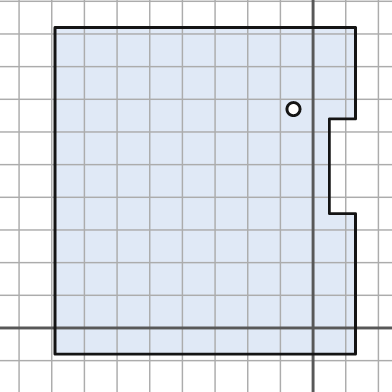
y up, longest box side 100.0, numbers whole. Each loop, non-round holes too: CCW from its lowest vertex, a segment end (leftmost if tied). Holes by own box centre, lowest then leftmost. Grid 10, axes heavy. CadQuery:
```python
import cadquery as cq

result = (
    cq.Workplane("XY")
    .moveTo(-79.0, -8.0)
    .lineTo(13.0, -8.0)
    .lineTo(13.0, 35.0)
    .lineTo(5.0, 35.0)
    .lineTo(5.0, 64.0)
    .lineTo(13.0, 64.0)
    .lineTo(13.0, 92.0)
    .lineTo(-79.0, 92.0)
    .close()
    .moveTo(-6.0, 67.0)
    .circle(2.0)
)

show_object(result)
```